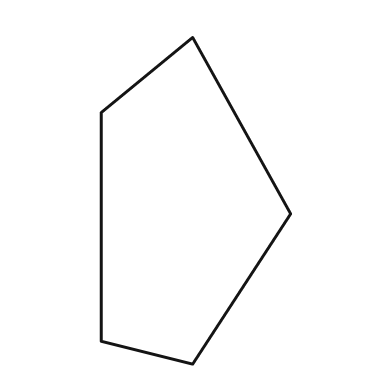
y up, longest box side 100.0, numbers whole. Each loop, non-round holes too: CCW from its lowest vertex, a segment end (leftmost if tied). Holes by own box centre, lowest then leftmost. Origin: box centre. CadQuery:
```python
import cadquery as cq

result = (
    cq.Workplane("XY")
    .moveTo(-1.0, -50.0)
    .lineTo(29.0, -4.0)
    .lineTo(-1.0, 50.0)
    .lineTo(-29.0, 27.0)
    .lineTo(-29.0, -43.0)
    .close()
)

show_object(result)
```